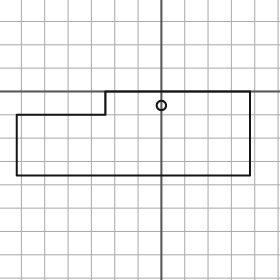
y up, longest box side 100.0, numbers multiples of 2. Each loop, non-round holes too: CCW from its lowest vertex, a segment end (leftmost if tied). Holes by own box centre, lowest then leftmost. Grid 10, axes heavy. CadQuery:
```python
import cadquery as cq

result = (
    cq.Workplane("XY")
    .moveTo(-62.0, -36.0)
    .lineTo(38.0, -36.0)
    .lineTo(38.0, 0.0)
    .lineTo(-24.0, 0.0)
    .lineTo(-24.0, -10.0)
    .lineTo(-62.0, -10.0)
    .close()
    .moveTo(0.0, -6.0)
    .circle(2.0)
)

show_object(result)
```